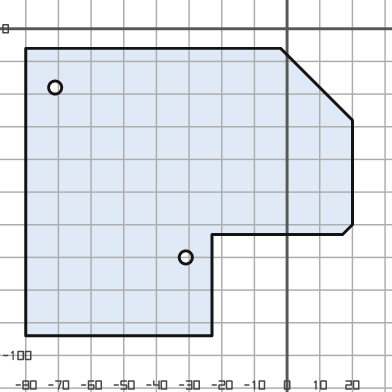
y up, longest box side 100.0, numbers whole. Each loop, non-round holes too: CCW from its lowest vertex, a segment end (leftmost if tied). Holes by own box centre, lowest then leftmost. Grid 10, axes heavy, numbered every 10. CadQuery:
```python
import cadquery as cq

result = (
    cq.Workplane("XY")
    .moveTo(-80.0, -94.0)
    .lineTo(-23.0, -94.0)
    .lineTo(-23.0, -63.0)
    .lineTo(17.0, -63.0)
    .lineTo(20.0, -60.0)
    .lineTo(20.0, -28.0)
    .lineTo(-2.0, -6.0)
    .lineTo(-80.0, -6.0)
    .close()
    .moveTo(-31.0, -70.0)
    .circle(2.0)
    .moveTo(-71.0, -18.0)
    .circle(2.0)
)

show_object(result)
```